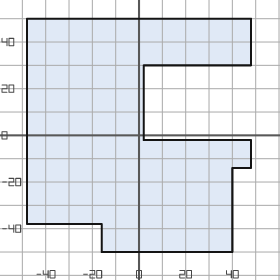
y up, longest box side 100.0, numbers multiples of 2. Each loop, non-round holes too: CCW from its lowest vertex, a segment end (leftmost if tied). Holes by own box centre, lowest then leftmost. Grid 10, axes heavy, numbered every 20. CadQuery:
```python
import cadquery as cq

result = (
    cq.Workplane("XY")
    .moveTo(-16.0, -50.0)
    .lineTo(40.0, -50.0)
    .lineTo(40.0, -14.0)
    .lineTo(48.0, -14.0)
    .lineTo(48.0, -2.0)
    .lineTo(2.0, -2.0)
    .lineTo(2.0, 30.0)
    .lineTo(48.0, 30.0)
    .lineTo(48.0, 50.0)
    .lineTo(-48.0, 50.0)
    .lineTo(-48.0, -38.0)
    .lineTo(-16.0, -38.0)
    .close()
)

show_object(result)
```